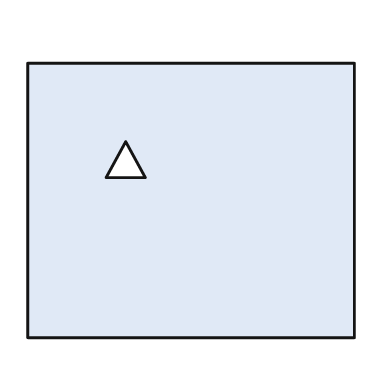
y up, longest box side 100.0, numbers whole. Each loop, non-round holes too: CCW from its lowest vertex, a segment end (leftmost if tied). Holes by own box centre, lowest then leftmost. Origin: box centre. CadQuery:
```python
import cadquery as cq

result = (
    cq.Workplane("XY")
    .moveTo(-50.0, -42.0)
    .lineTo(50.0, -42.0)
    .lineTo(50.0, 42.0)
    .lineTo(-50.0, 42.0)
    .close()
    .moveTo(-26.0, 7.0)
    .lineTo(-14.0, 7.0)
    .lineTo(-20.0, 18.0)
    .close()
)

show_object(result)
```